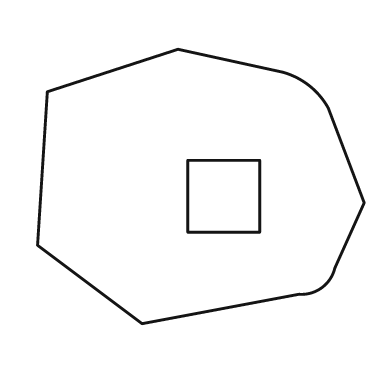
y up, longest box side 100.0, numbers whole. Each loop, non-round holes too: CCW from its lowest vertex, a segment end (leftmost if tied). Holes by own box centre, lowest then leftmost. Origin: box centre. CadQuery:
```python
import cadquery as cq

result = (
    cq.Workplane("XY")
    .moveTo(-18.0, -42.0)
    .lineTo(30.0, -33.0)
    .threePointArc((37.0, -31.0), (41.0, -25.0))
    .lineTo(50.0, -5.0)
    .lineTo(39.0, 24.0)
    .threePointArc((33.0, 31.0), (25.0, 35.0))
    .lineTo(-7.0, 42.0)
    .lineTo(-47.0, 29.0)
    .lineTo(-50.0, -18.0)
    .close()
    .moveTo(-4.0, -14.0)
    .lineTo(18.0, -14.0)
    .lineTo(18.0, 8.0)
    .lineTo(-4.0, 8.0)
    .close()
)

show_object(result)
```